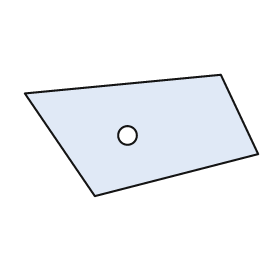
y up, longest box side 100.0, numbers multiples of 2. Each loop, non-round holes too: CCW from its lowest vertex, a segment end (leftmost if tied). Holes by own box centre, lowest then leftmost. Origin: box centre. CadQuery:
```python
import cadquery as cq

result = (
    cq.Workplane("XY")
    .moveTo(-20.0, -26.0)
    .lineTo(50.0, -8.0)
    .lineTo(34.0, 26.0)
    .lineTo(-50.0, 18.0)
    .close()
    .moveTo(-6.0, 0.0)
    .circle(4.0)
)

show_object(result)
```